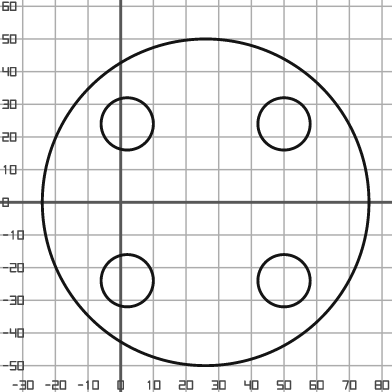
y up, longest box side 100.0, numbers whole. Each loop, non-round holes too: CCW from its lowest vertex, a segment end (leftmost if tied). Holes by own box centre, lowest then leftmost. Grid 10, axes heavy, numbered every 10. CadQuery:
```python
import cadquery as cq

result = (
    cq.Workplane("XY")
    .moveTo(26.0, 0.0)
    .circle(50.0)
    .moveTo(2.0, -24.0)
    .circle(8.0)
    .moveTo(50.0, -24.0)
    .circle(8.0)
    .moveTo(2.0, 24.0)
    .circle(8.0)
    .moveTo(50.0, 24.0)
    .circle(8.0)
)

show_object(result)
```